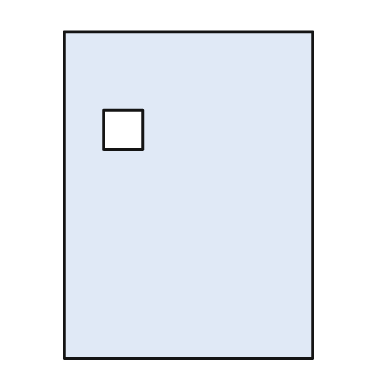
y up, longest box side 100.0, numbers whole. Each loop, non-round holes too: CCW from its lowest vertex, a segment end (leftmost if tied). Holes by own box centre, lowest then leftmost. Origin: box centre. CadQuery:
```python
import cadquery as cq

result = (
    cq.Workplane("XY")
    .moveTo(-38.0, -50.0)
    .lineTo(38.0, -50.0)
    .lineTo(38.0, 50.0)
    .lineTo(-38.0, 50.0)
    .close()
    .moveTo(-26.0, 14.0)
    .lineTo(-14.0, 14.0)
    .lineTo(-14.0, 26.0)
    .lineTo(-26.0, 26.0)
    .close()
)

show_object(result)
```